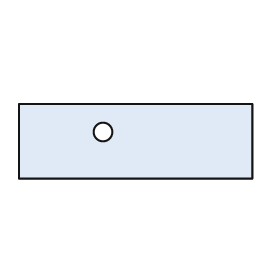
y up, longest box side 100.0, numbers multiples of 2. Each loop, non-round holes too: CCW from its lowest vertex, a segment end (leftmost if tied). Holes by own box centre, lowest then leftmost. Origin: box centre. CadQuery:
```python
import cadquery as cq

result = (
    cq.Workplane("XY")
    .moveTo(-50.0, -16.0)
    .lineTo(50.0, -16.0)
    .lineTo(50.0, 16.0)
    .lineTo(-50.0, 16.0)
    .close()
    .moveTo(-14.0, 4.0)
    .circle(4.0)
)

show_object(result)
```